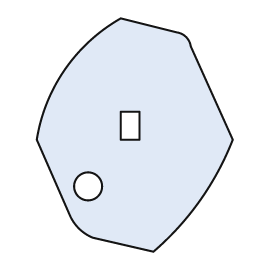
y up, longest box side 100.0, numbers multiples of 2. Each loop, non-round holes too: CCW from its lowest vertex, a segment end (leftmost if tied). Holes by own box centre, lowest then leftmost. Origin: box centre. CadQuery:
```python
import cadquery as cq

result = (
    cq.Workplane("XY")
    .moveTo(8.0, -50.0)
    .threePointArc((28.0, -28.0), (42.0, -2.0))
    .lineTo(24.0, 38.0)
    .threePointArc((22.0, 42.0), (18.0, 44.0))
    .lineTo(-6.0, 50.0)
    .threePointArc((-30.0, 28.0), (-42.0, -2.0))
    .lineTo(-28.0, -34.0)
    .threePointArc((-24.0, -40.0), (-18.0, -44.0))
    .close()
    .moveTo(-20.0, -22.0)
    .circle(6.0)
    .moveTo(-6.0, -2.0)
    .lineTo(2.0, -2.0)
    .lineTo(2.0, 10.0)
    .lineTo(-6.0, 10.0)
    .close()
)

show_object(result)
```